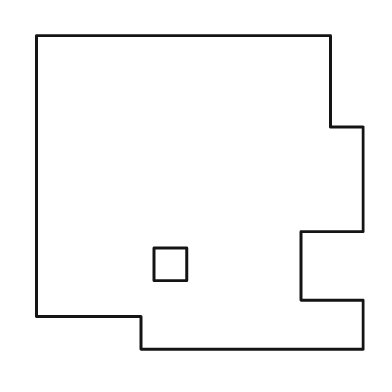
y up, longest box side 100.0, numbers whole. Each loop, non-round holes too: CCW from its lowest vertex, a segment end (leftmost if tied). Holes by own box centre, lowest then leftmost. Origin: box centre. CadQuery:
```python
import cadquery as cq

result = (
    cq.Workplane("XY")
    .moveTo(-18.0, -48.0)
    .lineTo(50.0, -48.0)
    .lineTo(50.0, -33.0)
    .lineTo(31.0, -33.0)
    .lineTo(31.0, -12.0)
    .lineTo(50.0, -12.0)
    .lineTo(50.0, 20.0)
    .lineTo(40.0, 20.0)
    .lineTo(40.0, 48.0)
    .lineTo(-50.0, 48.0)
    .lineTo(-50.0, -38.0)
    .lineTo(-18.0, -38.0)
    .close()
    .moveTo(-14.0, -27.0)
    .lineTo(-4.0, -27.0)
    .lineTo(-4.0, -17.0)
    .lineTo(-14.0, -17.0)
    .close()
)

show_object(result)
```